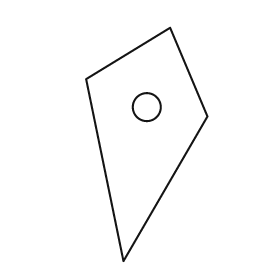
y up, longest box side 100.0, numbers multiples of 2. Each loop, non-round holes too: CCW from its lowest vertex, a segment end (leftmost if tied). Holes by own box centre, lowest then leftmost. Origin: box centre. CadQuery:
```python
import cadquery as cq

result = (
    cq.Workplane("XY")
    .moveTo(-10.0, -50.0)
    .lineTo(26.0, 12.0)
    .lineTo(10.0, 50.0)
    .lineTo(-26.0, 28.0)
    .close()
    .moveTo(0.0, 16.0)
    .circle(6.0)
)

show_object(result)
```